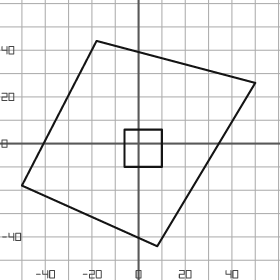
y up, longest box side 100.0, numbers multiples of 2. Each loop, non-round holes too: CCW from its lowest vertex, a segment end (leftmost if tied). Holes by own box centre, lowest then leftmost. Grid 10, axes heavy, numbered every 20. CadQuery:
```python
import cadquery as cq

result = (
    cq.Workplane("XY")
    .moveTo(8.0, -44.0)
    .lineTo(50.0, 26.0)
    .lineTo(-18.0, 44.0)
    .lineTo(-50.0, -18.0)
    .close()
    .moveTo(-6.0, -10.0)
    .lineTo(10.0, -10.0)
    .lineTo(10.0, 6.0)
    .lineTo(-6.0, 6.0)
    .close()
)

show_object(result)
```